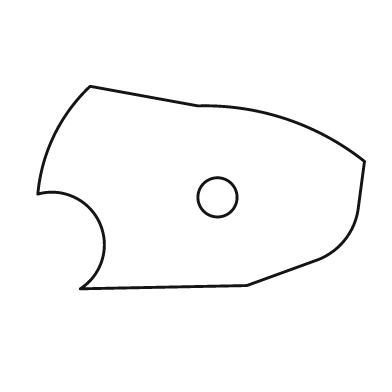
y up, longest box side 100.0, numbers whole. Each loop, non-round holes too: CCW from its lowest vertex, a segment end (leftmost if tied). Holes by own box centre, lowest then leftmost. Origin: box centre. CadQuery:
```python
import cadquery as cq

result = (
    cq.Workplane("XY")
    .moveTo(-37.0, -31.0)
    .lineTo(14.0, -30.0)
    .lineTo(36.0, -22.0)
    .threePointArc((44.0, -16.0), (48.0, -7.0))
    .lineTo(50.0, 8.0)
    .threePointArc((26.0, 21.0), (-1.0, 25.0))
    .lineTo(-34.0, 31.0)
    .threePointArc((-45.0, 16.0), (-50.0, -2.0))
    .threePointArc((-31.0, -11.0), (-37.0, -31.0))
    .close()
    .moveTo(5.0, -3.0)
    .circle(6.0)
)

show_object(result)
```